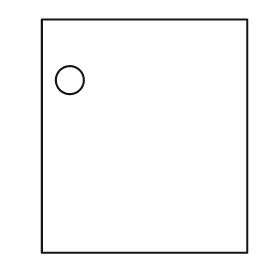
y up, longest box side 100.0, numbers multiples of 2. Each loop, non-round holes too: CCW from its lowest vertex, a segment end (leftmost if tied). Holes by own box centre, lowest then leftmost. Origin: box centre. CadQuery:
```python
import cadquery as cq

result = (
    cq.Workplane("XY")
    .moveTo(-44.0, -50.0)
    .lineTo(44.0, -50.0)
    .lineTo(44.0, 50.0)
    .lineTo(-44.0, 50.0)
    .close()
    .moveTo(-32.0, 24.0)
    .circle(6.0)
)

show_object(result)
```